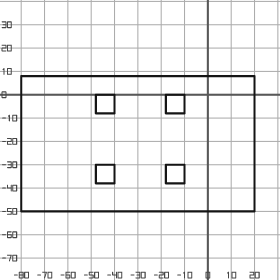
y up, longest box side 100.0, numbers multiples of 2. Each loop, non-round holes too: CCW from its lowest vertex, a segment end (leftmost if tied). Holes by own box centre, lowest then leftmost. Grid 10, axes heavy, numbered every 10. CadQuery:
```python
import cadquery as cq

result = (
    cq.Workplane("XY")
    .moveTo(-80.0, -50.0)
    .lineTo(20.0, -50.0)
    .lineTo(20.0, 8.0)
    .lineTo(-80.0, 8.0)
    .close()
    .moveTo(-48.0, -38.0)
    .lineTo(-40.0, -38.0)
    .lineTo(-40.0, -30.0)
    .lineTo(-48.0, -30.0)
    .close()
    .moveTo(-18.0, -38.0)
    .lineTo(-10.0, -38.0)
    .lineTo(-10.0, -30.0)
    .lineTo(-18.0, -30.0)
    .close()
    .moveTo(-48.0, -8.0)
    .lineTo(-40.0, -8.0)
    .lineTo(-40.0, 0.0)
    .lineTo(-48.0, 0.0)
    .close()
    .moveTo(-18.0, -8.0)
    .lineTo(-10.0, -8.0)
    .lineTo(-10.0, 0.0)
    .lineTo(-18.0, 0.0)
    .close()
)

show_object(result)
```